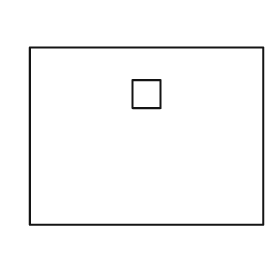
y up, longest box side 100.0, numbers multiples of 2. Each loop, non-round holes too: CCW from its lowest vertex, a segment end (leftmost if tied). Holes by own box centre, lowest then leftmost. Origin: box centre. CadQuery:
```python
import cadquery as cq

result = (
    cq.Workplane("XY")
    .moveTo(-50.0, -38.0)
    .lineTo(50.0, -38.0)
    .lineTo(50.0, 38.0)
    .lineTo(-50.0, 38.0)
    .close()
    .moveTo(-6.0, 12.0)
    .lineTo(6.0, 12.0)
    .lineTo(6.0, 24.0)
    .lineTo(-6.0, 24.0)
    .close()
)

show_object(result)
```